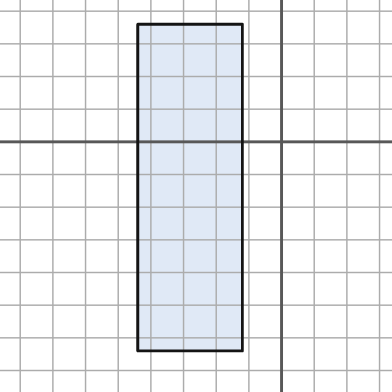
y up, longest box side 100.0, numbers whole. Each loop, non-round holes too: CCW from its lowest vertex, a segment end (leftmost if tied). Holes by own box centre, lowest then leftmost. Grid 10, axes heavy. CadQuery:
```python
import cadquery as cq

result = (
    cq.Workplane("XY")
    .moveTo(-44.0, -64.0)
    .lineTo(-12.0, -64.0)
    .lineTo(-12.0, 36.0)
    .lineTo(-44.0, 36.0)
    .close()
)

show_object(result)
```